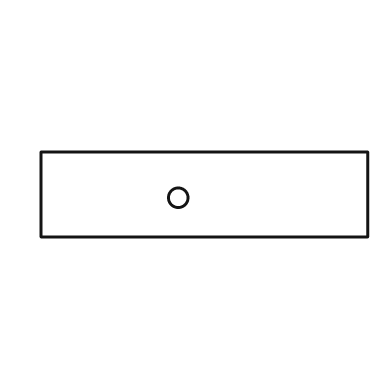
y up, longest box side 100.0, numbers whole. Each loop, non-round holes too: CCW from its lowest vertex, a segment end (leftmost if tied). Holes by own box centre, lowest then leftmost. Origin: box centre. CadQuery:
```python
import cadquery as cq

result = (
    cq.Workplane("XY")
    .moveTo(-50.0, -13.0)
    .lineTo(50.0, -13.0)
    .lineTo(50.0, 13.0)
    .lineTo(-50.0, 13.0)
    .close()
    .moveTo(-8.0, -1.0)
    .circle(3.0)
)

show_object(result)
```